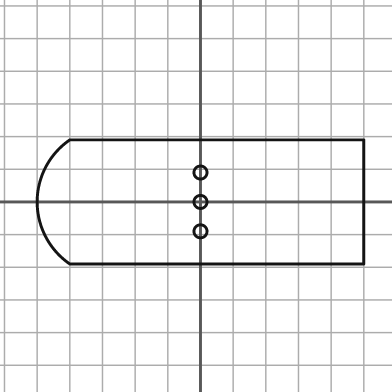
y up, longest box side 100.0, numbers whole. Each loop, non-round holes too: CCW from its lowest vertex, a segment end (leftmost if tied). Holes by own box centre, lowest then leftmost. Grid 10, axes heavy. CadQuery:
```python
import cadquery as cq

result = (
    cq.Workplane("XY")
    .moveTo(-40.0, -19.0)
    .lineTo(50.0, -19.0)
    .lineTo(50.0, 19.0)
    .lineTo(-40.0, 19.0)
    .threePointArc((-50.0, 0.0), (-40.0, -19.0))
    .close()
    .moveTo(0.0, -9.0)
    .circle(2.0)
    .moveTo(0.0, 0.0)
    .circle(2.0)
    .moveTo(0.0, 9.0)
    .circle(2.0)
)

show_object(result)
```